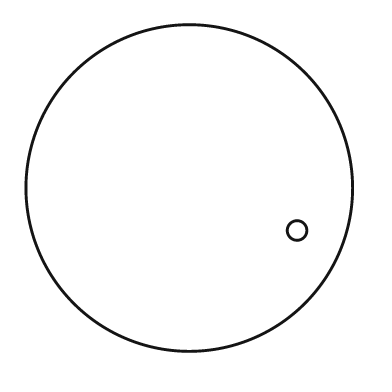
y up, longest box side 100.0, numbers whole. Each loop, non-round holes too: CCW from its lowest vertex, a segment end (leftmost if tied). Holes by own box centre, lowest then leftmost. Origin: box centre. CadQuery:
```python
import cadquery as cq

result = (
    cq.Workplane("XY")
    .moveTo(0.0, 0.0)
    .circle(50.0)
    .moveTo(33.0, -13.0)
    .circle(3.0)
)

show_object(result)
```